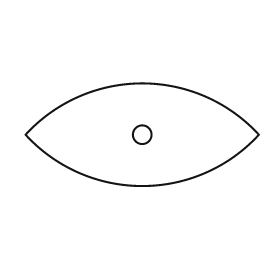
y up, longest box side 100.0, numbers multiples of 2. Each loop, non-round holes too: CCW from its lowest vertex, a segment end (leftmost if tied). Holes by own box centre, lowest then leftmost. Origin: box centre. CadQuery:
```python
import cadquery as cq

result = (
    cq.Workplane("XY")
    .moveTo(-50.0, 0.0)
    .threePointArc((0.0, -22.0), (50.0, 0.0))
    .threePointArc((0.0, 22.0), (-50.0, 0.0))
    .close()
    .moveTo(0.0, 0.0)
    .circle(4.0)
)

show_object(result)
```